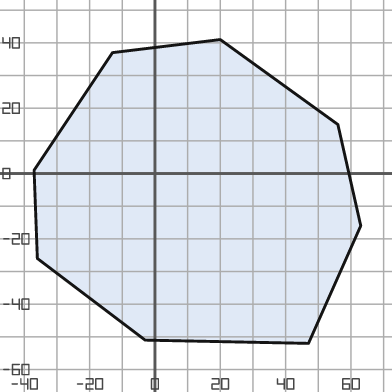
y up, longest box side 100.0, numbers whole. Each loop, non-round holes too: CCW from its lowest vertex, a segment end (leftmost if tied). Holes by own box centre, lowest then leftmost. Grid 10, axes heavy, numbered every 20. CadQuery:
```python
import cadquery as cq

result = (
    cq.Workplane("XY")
    .moveTo(47.0, -52.0)
    .lineTo(63.0, -16.0)
    .lineTo(56.0, 15.0)
    .lineTo(20.0, 41.0)
    .lineTo(-13.0, 37.0)
    .lineTo(-37.0, 1.0)
    .lineTo(-36.0, -26.0)
    .lineTo(-3.0, -51.0)
    .close()
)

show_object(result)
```